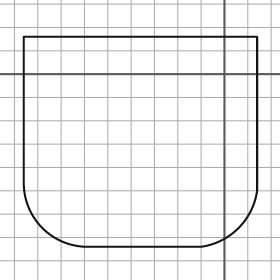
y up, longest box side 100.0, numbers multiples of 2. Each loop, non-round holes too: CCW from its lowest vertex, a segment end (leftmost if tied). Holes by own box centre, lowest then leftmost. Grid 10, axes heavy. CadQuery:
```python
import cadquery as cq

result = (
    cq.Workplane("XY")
    .moveTo(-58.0, -74.0)
    .lineTo(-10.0, -74.0)
    .threePointArc((6.0, -66.0), (14.0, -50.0))
    .lineTo(14.0, 16.0)
    .lineTo(-86.0, 16.0)
    .lineTo(-86.0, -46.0)
    .threePointArc((-78.0, -66.0), (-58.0, -74.0))
    .close()
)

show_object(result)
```